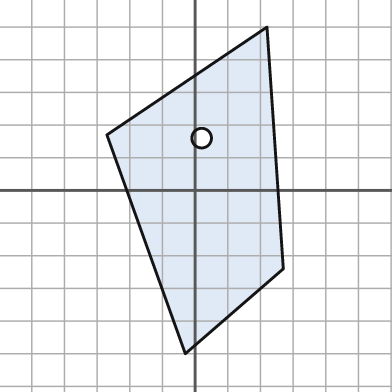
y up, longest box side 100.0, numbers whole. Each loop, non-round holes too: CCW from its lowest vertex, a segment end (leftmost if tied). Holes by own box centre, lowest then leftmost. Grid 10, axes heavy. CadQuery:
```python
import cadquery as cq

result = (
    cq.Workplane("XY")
    .moveTo(-3.0, -50.0)
    .lineTo(27.0, -24.0)
    .lineTo(22.0, 50.0)
    .lineTo(-27.0, 17.0)
    .close()
    .moveTo(2.0, 16.0)
    .circle(3.0)
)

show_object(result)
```